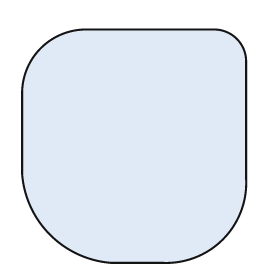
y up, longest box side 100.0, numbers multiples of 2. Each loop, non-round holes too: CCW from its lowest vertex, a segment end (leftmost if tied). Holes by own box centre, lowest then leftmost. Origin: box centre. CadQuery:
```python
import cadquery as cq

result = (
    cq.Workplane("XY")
    .moveTo(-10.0, -50.0)
    .lineTo(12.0, -50.0)
    .threePointArc((38.0, -40.0), (48.0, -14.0))
    .lineTo(48.0, 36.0)
    .threePointArc((44.0, 46.0), (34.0, 50.0))
    .lineTo(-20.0, 50.0)
    .threePointArc((-40.0, 42.0), (-48.0, 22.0))
    .lineTo(-48.0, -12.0)
    .threePointArc((-36.0, -38.0), (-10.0, -50.0))
    .close()
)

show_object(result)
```